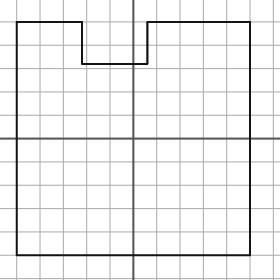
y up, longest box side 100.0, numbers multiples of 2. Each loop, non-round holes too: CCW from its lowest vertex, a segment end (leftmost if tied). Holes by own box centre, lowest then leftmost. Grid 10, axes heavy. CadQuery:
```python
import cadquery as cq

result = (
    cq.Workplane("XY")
    .moveTo(-50.0, -50.0)
    .lineTo(50.0, -50.0)
    .lineTo(50.0, 50.0)
    .lineTo(6.0, 50.0)
    .lineTo(6.0, 32.0)
    .lineTo(-22.0, 32.0)
    .lineTo(-22.0, 50.0)
    .lineTo(-50.0, 50.0)
    .close()
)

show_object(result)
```